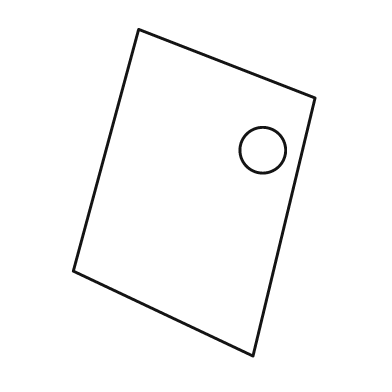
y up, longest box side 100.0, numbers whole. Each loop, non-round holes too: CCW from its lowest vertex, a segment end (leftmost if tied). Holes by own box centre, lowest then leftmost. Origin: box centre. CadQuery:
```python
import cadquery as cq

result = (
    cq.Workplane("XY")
    .moveTo(18.0, -50.0)
    .lineTo(37.0, 29.0)
    .lineTo(-17.0, 50.0)
    .lineTo(-37.0, -24.0)
    .close()
    .moveTo(21.0, 13.0)
    .circle(7.0)
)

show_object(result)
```